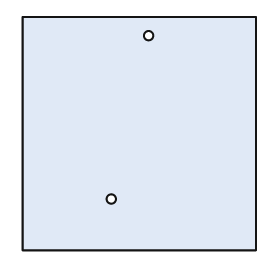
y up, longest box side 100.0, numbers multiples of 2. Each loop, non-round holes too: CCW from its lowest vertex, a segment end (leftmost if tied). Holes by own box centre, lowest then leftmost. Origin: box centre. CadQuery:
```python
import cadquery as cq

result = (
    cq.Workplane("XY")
    .moveTo(-50.0, -50.0)
    .lineTo(50.0, -50.0)
    .lineTo(50.0, 50.0)
    .lineTo(-50.0, 50.0)
    .close()
    .moveTo(-12.0, -28.0)
    .circle(2.0)
    .moveTo(4.0, 42.0)
    .circle(2.0)
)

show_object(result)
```